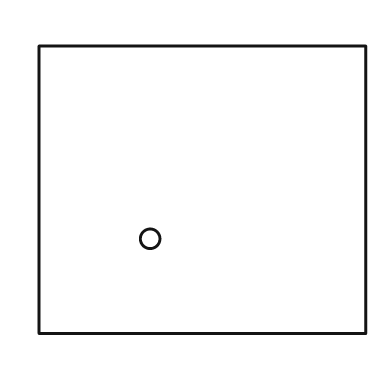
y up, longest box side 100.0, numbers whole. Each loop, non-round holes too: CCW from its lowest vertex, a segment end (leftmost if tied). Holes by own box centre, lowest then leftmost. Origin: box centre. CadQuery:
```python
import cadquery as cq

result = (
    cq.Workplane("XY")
    .moveTo(-50.0, -44.0)
    .lineTo(50.0, -44.0)
    .lineTo(50.0, 44.0)
    .lineTo(-50.0, 44.0)
    .close()
    .moveTo(-16.0, -15.0)
    .circle(3.0)
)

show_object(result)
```